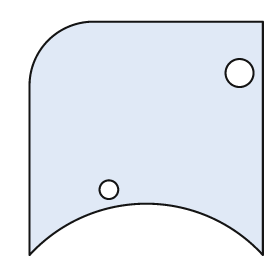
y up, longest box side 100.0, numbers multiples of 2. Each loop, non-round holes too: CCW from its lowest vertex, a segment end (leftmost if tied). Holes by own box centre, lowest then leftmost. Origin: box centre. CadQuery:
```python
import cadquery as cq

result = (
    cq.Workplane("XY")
    .moveTo(-50.0, -50.0)
    .threePointArc((0.0, -28.0), (50.0, -50.0))
    .lineTo(50.0, 50.0)
    .lineTo(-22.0, 50.0)
    .threePointArc((-42.0, 42.0), (-50.0, 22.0))
    .close()
    .moveTo(-16.0, -22.0)
    .circle(4.0)
    .moveTo(40.0, 28.0)
    .circle(6.0)
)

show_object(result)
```